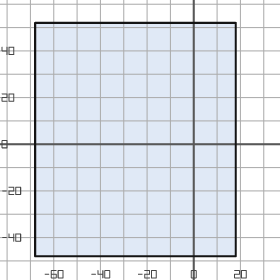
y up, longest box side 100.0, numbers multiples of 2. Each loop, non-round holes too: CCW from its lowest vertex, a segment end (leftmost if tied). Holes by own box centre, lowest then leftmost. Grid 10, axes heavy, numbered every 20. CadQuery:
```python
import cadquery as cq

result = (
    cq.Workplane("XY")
    .moveTo(-68.0, -48.0)
    .lineTo(18.0, -48.0)
    .lineTo(18.0, 52.0)
    .lineTo(-68.0, 52.0)
    .close()
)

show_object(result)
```